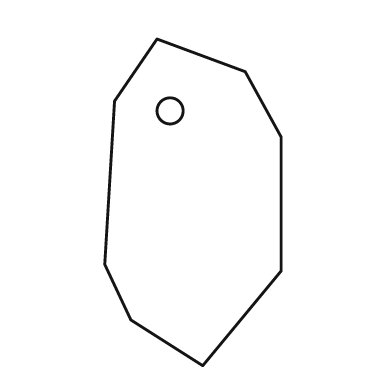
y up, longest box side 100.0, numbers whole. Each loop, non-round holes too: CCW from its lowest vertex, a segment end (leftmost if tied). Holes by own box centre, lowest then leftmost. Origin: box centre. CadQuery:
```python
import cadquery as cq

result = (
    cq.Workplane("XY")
    .moveTo(3.0, -50.0)
    .lineTo(27.0, -21.0)
    .lineTo(27.0, 20.0)
    .lineTo(16.0, 40.0)
    .lineTo(-11.0, 50.0)
    .lineTo(-24.0, 31.0)
    .lineTo(-27.0, -19.0)
    .lineTo(-19.0, -36.0)
    .close()
    .moveTo(-7.0, 28.0)
    .circle(4.0)
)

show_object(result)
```